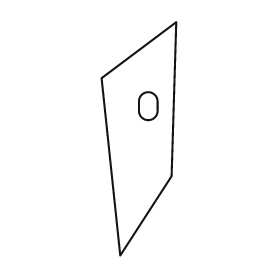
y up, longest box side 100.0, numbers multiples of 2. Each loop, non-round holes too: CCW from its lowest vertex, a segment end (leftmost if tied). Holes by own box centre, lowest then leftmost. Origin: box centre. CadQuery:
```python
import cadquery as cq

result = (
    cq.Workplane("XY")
    .moveTo(-8.0, -50.0)
    .lineTo(14.0, -16.0)
    .lineTo(16.0, 50.0)
    .lineTo(-16.0, 26.0)
    .close()
    .moveTo(0.0, 12.0)
    .threePointArc((4.0, 8.0), (8.0, 12.0))
    .lineTo(8.0, 16.0)
    .threePointArc((4.0, 20.0), (0.0, 16.0))
    .close()
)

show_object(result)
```